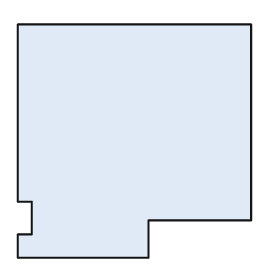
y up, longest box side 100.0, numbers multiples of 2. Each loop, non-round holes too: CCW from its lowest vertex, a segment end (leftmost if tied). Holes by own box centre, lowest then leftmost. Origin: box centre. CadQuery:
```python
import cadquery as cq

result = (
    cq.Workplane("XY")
    .moveTo(-50.0, -50.0)
    .lineTo(6.0, -50.0)
    .lineTo(6.0, -34.0)
    .lineTo(50.0, -34.0)
    .lineTo(50.0, 50.0)
    .lineTo(-50.0, 50.0)
    .lineTo(-50.0, -26.0)
    .lineTo(-44.0, -26.0)
    .lineTo(-44.0, -40.0)
    .lineTo(-50.0, -40.0)
    .close()
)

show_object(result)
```